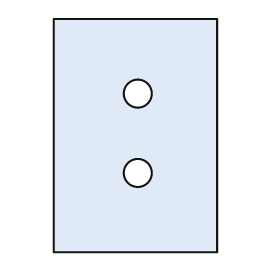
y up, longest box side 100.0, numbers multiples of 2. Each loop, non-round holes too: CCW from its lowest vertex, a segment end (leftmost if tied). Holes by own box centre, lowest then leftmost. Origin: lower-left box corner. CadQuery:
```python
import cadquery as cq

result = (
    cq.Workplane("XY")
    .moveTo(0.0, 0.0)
    .lineTo(70.0, 0.0)
    .lineTo(70.0, 100.0)
    .lineTo(0.0, 100.0)
    .close()
    .moveTo(36.0, 34.0)
    .circle(6.0)
    .moveTo(36.0, 68.0)
    .circle(6.0)
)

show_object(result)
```